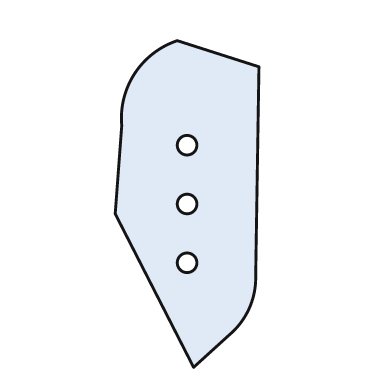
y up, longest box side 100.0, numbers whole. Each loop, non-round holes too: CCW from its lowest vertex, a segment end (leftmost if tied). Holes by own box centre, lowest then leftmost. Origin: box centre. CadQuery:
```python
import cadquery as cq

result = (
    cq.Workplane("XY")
    .moveTo(2.0, -50.0)
    .lineTo(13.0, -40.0)
    .threePointArc((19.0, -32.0), (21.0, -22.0))
    .lineTo(22.0, 42.0)
    .lineTo(-3.0, 50.0)
    .threePointArc((-16.0, 40.0), (-20.0, 24.0))
    .lineTo(-22.0, -3.0)
    .close()
    .moveTo(0.0, -18.0)
    .circle(3.0)
    .moveTo(0.0, 0.0)
    .circle(3.0)
    .moveTo(0.0, 18.0)
    .circle(3.0)
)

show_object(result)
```